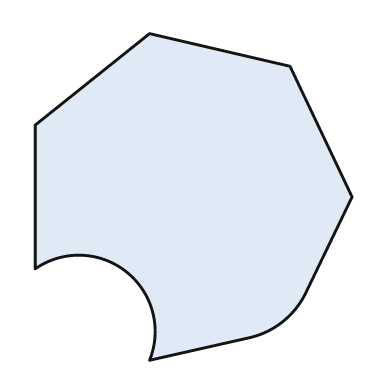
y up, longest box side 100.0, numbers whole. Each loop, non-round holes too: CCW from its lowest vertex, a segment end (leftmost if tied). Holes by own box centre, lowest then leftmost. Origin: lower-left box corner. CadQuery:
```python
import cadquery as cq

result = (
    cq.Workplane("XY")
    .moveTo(35.0, 0.0)
    .lineTo(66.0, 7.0)
    .threePointArc((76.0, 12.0), (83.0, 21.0))
    .lineTo(97.0, 50.0)
    .lineTo(78.0, 90.0)
    .lineTo(35.0, 100.0)
    .lineTo(0.0, 72.0)
    .lineTo(0.0, 28.0)
    .threePointArc((28.0, 27.0), (35.0, 0.0))
    .close()
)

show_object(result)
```